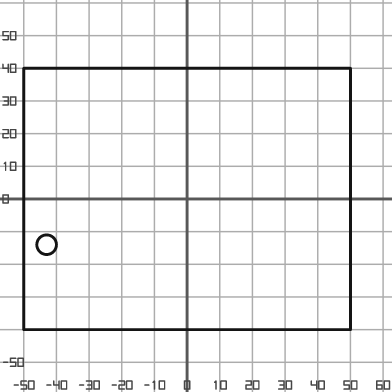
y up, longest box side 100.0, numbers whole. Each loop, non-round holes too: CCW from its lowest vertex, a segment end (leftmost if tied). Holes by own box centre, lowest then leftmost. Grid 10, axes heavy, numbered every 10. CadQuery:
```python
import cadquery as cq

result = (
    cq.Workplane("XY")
    .moveTo(-50.0, -40.0)
    .lineTo(50.0, -40.0)
    .lineTo(50.0, 40.0)
    .lineTo(-50.0, 40.0)
    .close()
    .moveTo(-43.0, -14.0)
    .circle(3.0)
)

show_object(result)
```